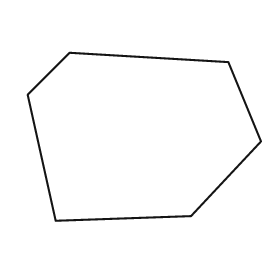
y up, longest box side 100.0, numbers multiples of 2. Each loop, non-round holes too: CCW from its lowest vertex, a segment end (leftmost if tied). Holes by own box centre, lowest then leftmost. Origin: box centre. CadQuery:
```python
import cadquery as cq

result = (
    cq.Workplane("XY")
    .moveTo(-38.0, -36.0)
    .lineTo(20.0, -34.0)
    .lineTo(50.0, -2.0)
    .lineTo(36.0, 32.0)
    .lineTo(-32.0, 36.0)
    .lineTo(-50.0, 18.0)
    .close()
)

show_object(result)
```